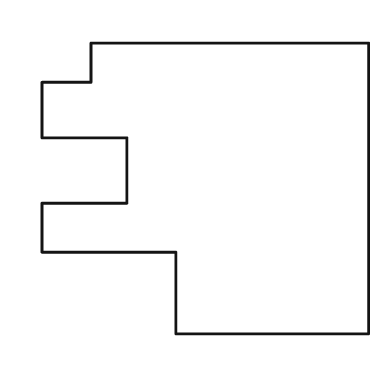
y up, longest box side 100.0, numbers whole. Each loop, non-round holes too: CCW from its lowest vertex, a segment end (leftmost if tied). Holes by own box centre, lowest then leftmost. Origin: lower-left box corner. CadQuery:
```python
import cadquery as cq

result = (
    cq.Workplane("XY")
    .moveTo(41.0, 0.0)
    .lineTo(100.0, 0.0)
    .lineTo(100.0, 89.0)
    .lineTo(15.0, 89.0)
    .lineTo(15.0, 77.0)
    .lineTo(0.0, 77.0)
    .lineTo(0.0, 60.0)
    .lineTo(26.0, 60.0)
    .lineTo(26.0, 40.0)
    .lineTo(0.0, 40.0)
    .lineTo(0.0, 25.0)
    .lineTo(41.0, 25.0)
    .close()
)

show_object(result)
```